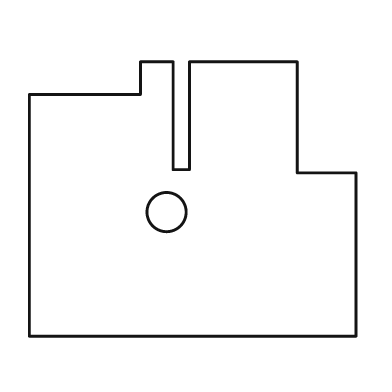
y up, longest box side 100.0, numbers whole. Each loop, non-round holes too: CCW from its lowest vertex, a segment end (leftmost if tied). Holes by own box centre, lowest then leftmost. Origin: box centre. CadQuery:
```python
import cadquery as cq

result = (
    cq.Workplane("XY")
    .moveTo(-50.0, -42.0)
    .lineTo(50.0, -42.0)
    .lineTo(50.0, 8.0)
    .lineTo(32.0, 8.0)
    .lineTo(32.0, 42.0)
    .lineTo(-1.0, 42.0)
    .lineTo(-1.0, 9.0)
    .lineTo(-6.0, 9.0)
    .lineTo(-6.0, 42.0)
    .lineTo(-16.0, 42.0)
    .lineTo(-16.0, 32.0)
    .lineTo(-50.0, 32.0)
    .close()
    .moveTo(-8.0, -4.0)
    .circle(6.0)
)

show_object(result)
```